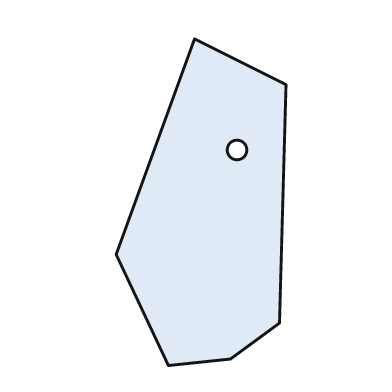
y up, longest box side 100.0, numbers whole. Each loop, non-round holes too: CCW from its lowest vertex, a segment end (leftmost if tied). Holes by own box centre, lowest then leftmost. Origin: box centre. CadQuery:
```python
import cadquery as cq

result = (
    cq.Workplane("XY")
    .moveTo(-10.0, -50.0)
    .lineTo(9.0, -48.0)
    .lineTo(24.0, -37.0)
    .lineTo(26.0, 36.0)
    .lineTo(-2.0, 50.0)
    .lineTo(-26.0, -16.0)
    .close()
    .moveTo(11.0, 16.0)
    .circle(3.0)
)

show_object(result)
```